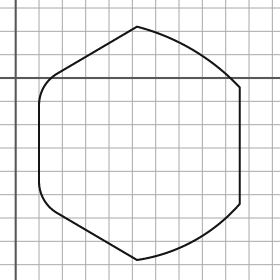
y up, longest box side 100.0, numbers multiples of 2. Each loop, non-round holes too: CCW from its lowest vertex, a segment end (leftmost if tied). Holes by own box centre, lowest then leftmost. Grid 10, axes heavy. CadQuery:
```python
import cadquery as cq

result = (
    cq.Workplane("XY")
    .moveTo(52.0, -78.0)
    .threePointArc((76.0, -70.0), (96.0, -54.0))
    .lineTo(96.0, -4.0)
    .threePointArc((76.0, 12.0), (52.0, 22.0))
    .lineTo(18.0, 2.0)
    .threePointArc((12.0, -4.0), (10.0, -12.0))
    .lineTo(10.0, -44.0)
    .threePointArc((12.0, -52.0), (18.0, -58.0))
    .close()
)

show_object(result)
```